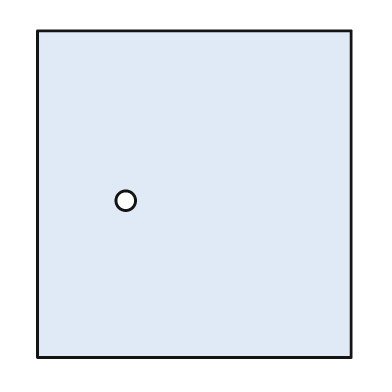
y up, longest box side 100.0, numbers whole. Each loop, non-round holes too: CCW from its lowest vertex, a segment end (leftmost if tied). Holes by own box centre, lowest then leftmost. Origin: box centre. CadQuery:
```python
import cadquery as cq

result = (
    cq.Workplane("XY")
    .moveTo(-48.0, -50.0)
    .lineTo(48.0, -50.0)
    .lineTo(48.0, 50.0)
    .lineTo(-48.0, 50.0)
    .close()
    .moveTo(-21.0, -2.0)
    .circle(3.0)
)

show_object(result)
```